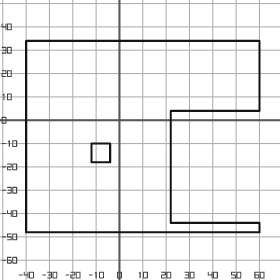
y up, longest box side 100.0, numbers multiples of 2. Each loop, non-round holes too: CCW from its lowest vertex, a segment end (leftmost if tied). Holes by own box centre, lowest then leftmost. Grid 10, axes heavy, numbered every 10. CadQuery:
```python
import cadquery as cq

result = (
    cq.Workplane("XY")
    .moveTo(-40.0, -48.0)
    .lineTo(60.0, -48.0)
    .lineTo(60.0, -44.0)
    .lineTo(22.0, -44.0)
    .lineTo(22.0, 4.0)
    .lineTo(60.0, 4.0)
    .lineTo(60.0, 34.0)
    .lineTo(-40.0, 34.0)
    .close()
    .moveTo(-12.0, -18.0)
    .lineTo(-4.0, -18.0)
    .lineTo(-4.0, -10.0)
    .lineTo(-12.0, -10.0)
    .close()
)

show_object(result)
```